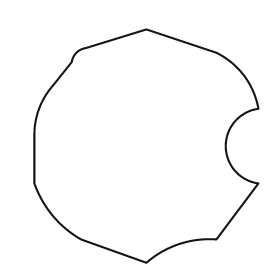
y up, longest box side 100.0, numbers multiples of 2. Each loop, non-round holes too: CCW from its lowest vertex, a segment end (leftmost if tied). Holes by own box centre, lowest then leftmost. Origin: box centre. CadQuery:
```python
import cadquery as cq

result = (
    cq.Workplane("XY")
    .moveTo(0.0, -50.0)
    .threePointArc((14.0, -42.0), (30.0, -40.0))
    .lineTo(48.0, -16.0)
    .threePointArc((34.0, 0.0), (48.0, 16.0))
    .threePointArc((42.0, 30.0), (30.0, 40.0))
    .lineTo(0.0, 50.0)
    .lineTo(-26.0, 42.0)
    .threePointArc((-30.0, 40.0), (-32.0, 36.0))
    .lineTo(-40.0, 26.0)
    .threePointArc((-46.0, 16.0), (-48.0, 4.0))
    .lineTo(-48.0, -16.0)
    .threePointArc((-40.0, -30.0), (-28.0, -40.0))
    .close()
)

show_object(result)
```